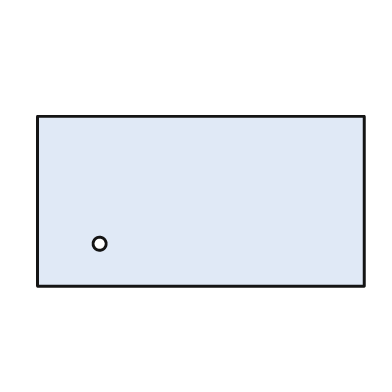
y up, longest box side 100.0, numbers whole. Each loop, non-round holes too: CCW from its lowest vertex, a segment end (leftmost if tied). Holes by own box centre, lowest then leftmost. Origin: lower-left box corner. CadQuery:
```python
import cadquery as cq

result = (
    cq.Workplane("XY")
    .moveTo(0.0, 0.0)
    .lineTo(100.0, 0.0)
    .lineTo(100.0, 52.0)
    .lineTo(0.0, 52.0)
    .close()
    .moveTo(19.0, 13.0)
    .circle(2.0)
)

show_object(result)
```